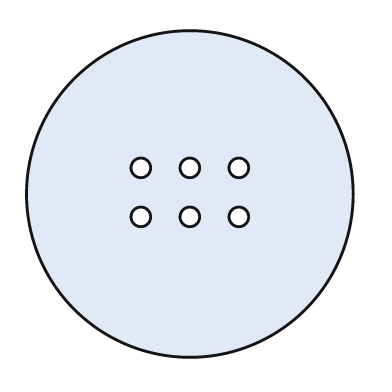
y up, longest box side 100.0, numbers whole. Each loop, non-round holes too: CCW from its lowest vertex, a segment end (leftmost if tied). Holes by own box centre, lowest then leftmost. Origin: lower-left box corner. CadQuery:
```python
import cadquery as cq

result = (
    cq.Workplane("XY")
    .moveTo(50.0, 50.0)
    .circle(50.0)
    .moveTo(35.0, 43.0)
    .circle(3.0)
    .moveTo(50.0, 43.0)
    .circle(3.0)
    .moveTo(65.0, 43.0)
    .circle(3.0)
    .moveTo(35.0, 58.0)
    .circle(3.0)
    .moveTo(50.0, 58.0)
    .circle(3.0)
    .moveTo(65.0, 58.0)
    .circle(3.0)
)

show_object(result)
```